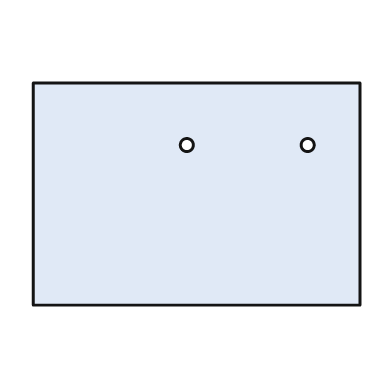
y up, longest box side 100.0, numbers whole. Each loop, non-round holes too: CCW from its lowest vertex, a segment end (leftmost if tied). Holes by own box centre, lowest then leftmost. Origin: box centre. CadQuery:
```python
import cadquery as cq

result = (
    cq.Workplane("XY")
    .moveTo(-50.0, -34.0)
    .lineTo(50.0, -34.0)
    .lineTo(50.0, 34.0)
    .lineTo(-50.0, 34.0)
    .close()
    .moveTo(-3.0, 15.0)
    .circle(2.0)
    .moveTo(34.0, 15.0)
    .circle(2.0)
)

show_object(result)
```